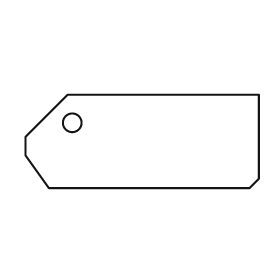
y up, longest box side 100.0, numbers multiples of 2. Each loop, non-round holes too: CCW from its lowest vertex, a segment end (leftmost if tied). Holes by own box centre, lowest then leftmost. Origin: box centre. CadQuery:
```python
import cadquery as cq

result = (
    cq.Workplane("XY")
    .moveTo(-40.0, -20.0)
    .lineTo(46.0, -20.0)
    .lineTo(50.0, -16.0)
    .lineTo(50.0, 20.0)
    .lineTo(-32.0, 20.0)
    .lineTo(-50.0, 2.0)
    .lineTo(-50.0, -6.0)
    .close()
    .moveTo(-30.0, 8.0)
    .circle(4.0)
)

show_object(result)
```